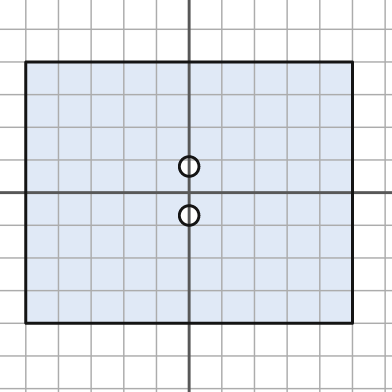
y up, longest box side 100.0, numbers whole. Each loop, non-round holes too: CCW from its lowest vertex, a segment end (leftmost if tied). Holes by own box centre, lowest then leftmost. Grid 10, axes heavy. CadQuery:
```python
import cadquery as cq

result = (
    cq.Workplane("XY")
    .moveTo(-50.0, -40.0)
    .lineTo(50.0, -40.0)
    .lineTo(50.0, 40.0)
    .lineTo(-50.0, 40.0)
    .close()
    .moveTo(0.0, -7.0)
    .circle(3.0)
    .moveTo(0.0, 8.0)
    .circle(3.0)
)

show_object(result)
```